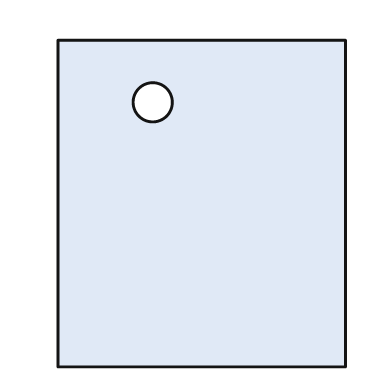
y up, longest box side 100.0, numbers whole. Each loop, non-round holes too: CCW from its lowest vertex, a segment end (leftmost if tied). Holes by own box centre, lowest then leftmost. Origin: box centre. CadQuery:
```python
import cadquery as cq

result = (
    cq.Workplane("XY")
    .moveTo(-44.0, -50.0)
    .lineTo(44.0, -50.0)
    .lineTo(44.0, 50.0)
    .lineTo(-44.0, 50.0)
    .close()
    .moveTo(-15.0, 31.0)
    .circle(6.0)
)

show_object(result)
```